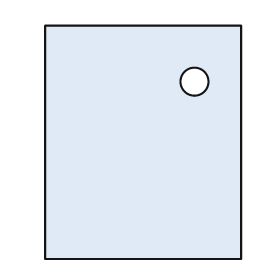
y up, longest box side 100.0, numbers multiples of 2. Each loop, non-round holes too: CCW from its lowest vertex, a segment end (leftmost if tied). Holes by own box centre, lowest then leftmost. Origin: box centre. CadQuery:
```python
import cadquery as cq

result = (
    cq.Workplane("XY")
    .moveTo(-42.0, -50.0)
    .lineTo(42.0, -50.0)
    .lineTo(42.0, 50.0)
    .lineTo(-42.0, 50.0)
    .close()
    .moveTo(22.0, 26.0)
    .circle(6.0)
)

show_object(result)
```